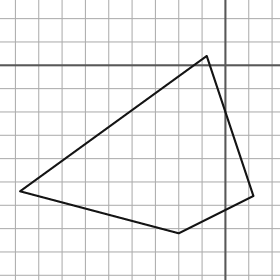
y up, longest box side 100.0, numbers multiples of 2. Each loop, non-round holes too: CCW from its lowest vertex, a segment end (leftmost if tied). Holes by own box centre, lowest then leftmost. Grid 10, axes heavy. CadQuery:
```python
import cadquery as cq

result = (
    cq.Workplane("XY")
    .moveTo(-20.0, -72.0)
    .lineTo(12.0, -56.0)
    .lineTo(-8.0, 4.0)
    .lineTo(-88.0, -54.0)
    .close()
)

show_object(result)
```